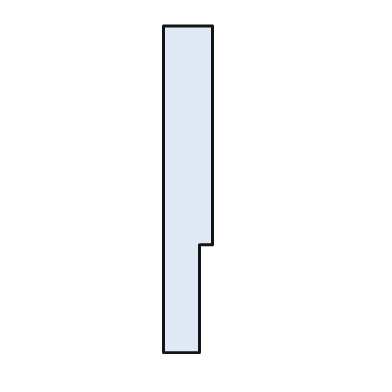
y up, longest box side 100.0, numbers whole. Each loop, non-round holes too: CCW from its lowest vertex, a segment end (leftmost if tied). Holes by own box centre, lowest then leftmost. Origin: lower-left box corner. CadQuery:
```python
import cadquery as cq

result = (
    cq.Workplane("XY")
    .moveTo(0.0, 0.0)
    .lineTo(11.0, 0.0)
    .lineTo(11.0, 33.0)
    .lineTo(15.0, 33.0)
    .lineTo(15.0, 100.0)
    .lineTo(0.0, 100.0)
    .close()
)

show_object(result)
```